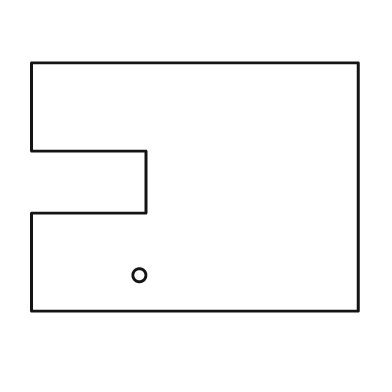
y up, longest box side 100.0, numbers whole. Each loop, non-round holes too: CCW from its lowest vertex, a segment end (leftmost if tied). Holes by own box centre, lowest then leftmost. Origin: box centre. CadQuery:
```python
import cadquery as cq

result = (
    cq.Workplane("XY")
    .moveTo(-50.0, -38.0)
    .lineTo(50.0, -38.0)
    .lineTo(50.0, 38.0)
    .lineTo(-50.0, 38.0)
    .lineTo(-50.0, 11.0)
    .lineTo(-15.0, 11.0)
    .lineTo(-15.0, -8.0)
    .lineTo(-50.0, -8.0)
    .close()
    .moveTo(-17.0, -27.0)
    .circle(2.0)
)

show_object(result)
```